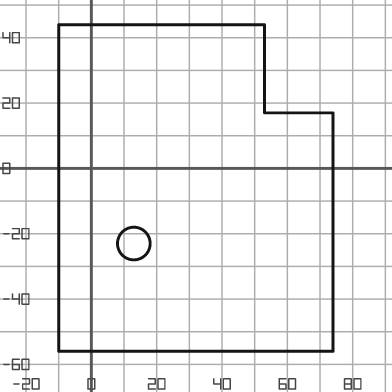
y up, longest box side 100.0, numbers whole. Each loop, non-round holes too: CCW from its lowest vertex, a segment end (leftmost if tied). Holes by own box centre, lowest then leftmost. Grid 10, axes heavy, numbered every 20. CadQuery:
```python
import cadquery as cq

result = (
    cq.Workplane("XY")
    .moveTo(-10.0, -56.0)
    .lineTo(74.0, -56.0)
    .lineTo(74.0, 17.0)
    .lineTo(53.0, 17.0)
    .lineTo(53.0, 44.0)
    .lineTo(-10.0, 44.0)
    .close()
    .moveTo(13.0, -23.0)
    .circle(5.0)
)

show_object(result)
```